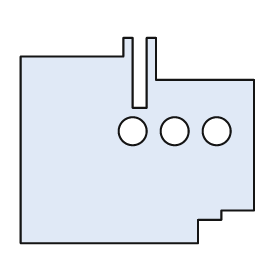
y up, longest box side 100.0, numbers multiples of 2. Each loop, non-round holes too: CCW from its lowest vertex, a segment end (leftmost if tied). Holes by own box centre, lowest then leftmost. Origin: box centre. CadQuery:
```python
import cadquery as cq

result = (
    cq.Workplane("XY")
    .moveTo(-50.0, -44.0)
    .lineTo(26.0, -44.0)
    .lineTo(26.0, -34.0)
    .lineTo(36.0, -34.0)
    .lineTo(36.0, -30.0)
    .lineTo(50.0, -30.0)
    .lineTo(50.0, 26.0)
    .lineTo(8.0, 26.0)
    .lineTo(8.0, 44.0)
    .lineTo(4.0, 44.0)
    .lineTo(4.0, 14.0)
    .lineTo(-2.0, 14.0)
    .lineTo(-2.0, 44.0)
    .lineTo(-6.0, 44.0)
    .lineTo(-6.0, 36.0)
    .lineTo(-50.0, 36.0)
    .close()
    .moveTo(-2.0, 4.0)
    .circle(6.0)
    .moveTo(16.0, 4.0)
    .circle(6.0)
    .moveTo(34.0, 4.0)
    .circle(6.0)
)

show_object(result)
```